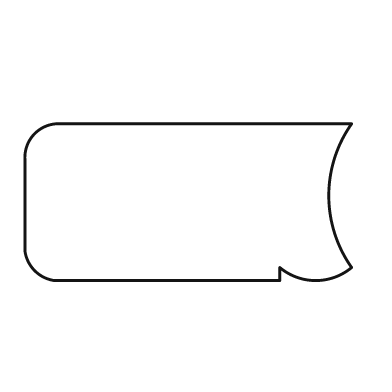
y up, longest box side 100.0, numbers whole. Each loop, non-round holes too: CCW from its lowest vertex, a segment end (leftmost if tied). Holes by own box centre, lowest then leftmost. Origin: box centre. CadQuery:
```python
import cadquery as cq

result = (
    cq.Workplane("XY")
    .moveTo(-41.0, -24.0)
    .lineTo(28.0, -24.0)
    .lineTo(28.0, -20.0)
    .threePointArc((39.0, -24.0), (50.0, -20.0))
    .threePointArc((43.0, 2.0), (50.0, 24.0))
    .lineTo(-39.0, 24.0)
    .threePointArc((-47.0, 21.0), (-50.0, 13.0))
    .lineTo(-50.0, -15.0)
    .threePointArc((-47.0, -21.0), (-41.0, -24.0))
    .close()
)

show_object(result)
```